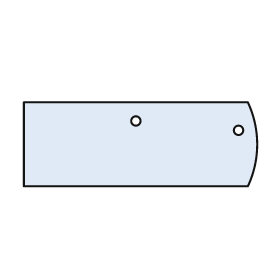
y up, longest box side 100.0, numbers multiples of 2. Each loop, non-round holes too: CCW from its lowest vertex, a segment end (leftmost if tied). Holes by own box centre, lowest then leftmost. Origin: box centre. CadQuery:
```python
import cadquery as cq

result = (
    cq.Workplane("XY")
    .moveTo(-50.0, -18.0)
    .lineTo(46.0, -18.0)
    .threePointArc((50.0, 0.0), (46.0, 18.0))
    .lineTo(-50.0, 18.0)
    .close()
    .moveTo(42.0, 6.0)
    .circle(2.0)
    .moveTo(-2.0, 10.0)
    .circle(2.0)
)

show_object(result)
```